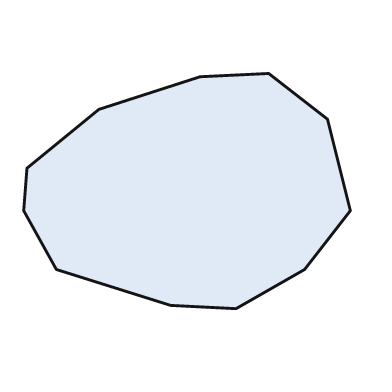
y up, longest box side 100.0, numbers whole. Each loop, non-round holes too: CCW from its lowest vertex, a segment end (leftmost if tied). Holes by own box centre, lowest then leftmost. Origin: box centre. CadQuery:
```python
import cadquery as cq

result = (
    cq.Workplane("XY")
    .moveTo(15.0, -36.0)
    .lineTo(36.0, -24.0)
    .lineTo(50.0, -6.0)
    .lineTo(43.0, 22.0)
    .lineTo(25.0, 36.0)
    .lineTo(4.0, 35.0)
    .lineTo(-27.0, 25.0)
    .lineTo(-49.0, 7.0)
    .lineTo(-50.0, -6.0)
    .lineTo(-40.0, -24.0)
    .lineTo(-5.0, -35.0)
    .close()
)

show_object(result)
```